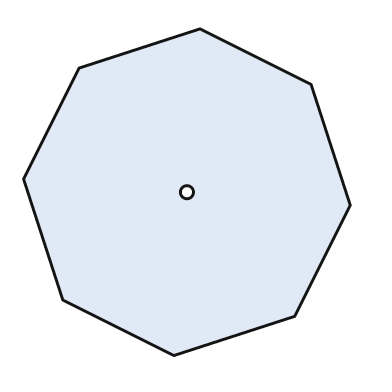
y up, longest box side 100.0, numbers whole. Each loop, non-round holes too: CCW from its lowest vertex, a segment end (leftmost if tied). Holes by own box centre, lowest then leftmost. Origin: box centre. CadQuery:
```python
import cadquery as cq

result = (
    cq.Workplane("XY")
    .moveTo(-4.0, -50.0)
    .lineTo(33.0, -38.0)
    .lineTo(50.0, -4.0)
    .lineTo(38.0, 33.0)
    .lineTo(4.0, 50.0)
    .lineTo(-33.0, 38.0)
    .lineTo(-50.0, 4.0)
    .lineTo(-38.0, -33.0)
    .close()
    .moveTo(0.0, 0.0)
    .circle(2.0)
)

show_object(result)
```